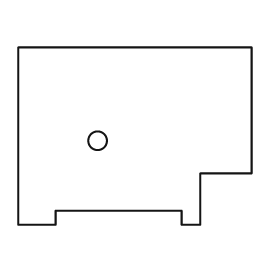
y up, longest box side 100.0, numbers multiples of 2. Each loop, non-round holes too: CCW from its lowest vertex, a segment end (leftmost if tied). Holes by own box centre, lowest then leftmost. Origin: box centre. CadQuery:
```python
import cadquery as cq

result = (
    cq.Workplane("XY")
    .moveTo(-50.0, -38.0)
    .lineTo(-34.0, -38.0)
    .lineTo(-34.0, -32.0)
    .lineTo(20.0, -32.0)
    .lineTo(20.0, -38.0)
    .lineTo(28.0, -38.0)
    .lineTo(28.0, -16.0)
    .lineTo(50.0, -16.0)
    .lineTo(50.0, 38.0)
    .lineTo(-50.0, 38.0)
    .close()
    .moveTo(-16.0, -2.0)
    .circle(4.0)
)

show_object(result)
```